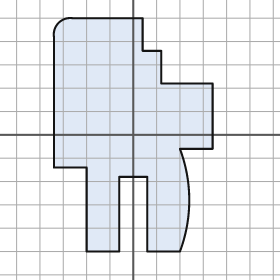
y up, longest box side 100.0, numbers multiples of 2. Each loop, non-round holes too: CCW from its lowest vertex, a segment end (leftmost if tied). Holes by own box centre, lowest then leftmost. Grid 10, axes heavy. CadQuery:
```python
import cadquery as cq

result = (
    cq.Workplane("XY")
    .moveTo(-20.0, -50.0)
    .lineTo(-6.0, -50.0)
    .lineTo(-6.0, -18.0)
    .lineTo(6.0, -18.0)
    .lineTo(6.0, -50.0)
    .lineTo(20.0, -50.0)
    .threePointArc((24.0, -28.0), (20.0, -6.0))
    .lineTo(34.0, -6.0)
    .lineTo(34.0, 22.0)
    .lineTo(12.0, 22.0)
    .lineTo(12.0, 36.0)
    .lineTo(4.0, 36.0)
    .lineTo(4.0, 50.0)
    .lineTo(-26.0, 50.0)
    .threePointArc((-32.0, 48.0), (-34.0, 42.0))
    .lineTo(-34.0, -14.0)
    .lineTo(-20.0, -14.0)
    .close()
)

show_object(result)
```